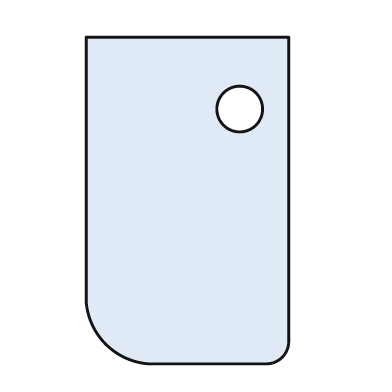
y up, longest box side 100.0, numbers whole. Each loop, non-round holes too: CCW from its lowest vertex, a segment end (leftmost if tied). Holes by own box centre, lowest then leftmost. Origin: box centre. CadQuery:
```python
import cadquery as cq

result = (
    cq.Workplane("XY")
    .moveTo(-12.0, -50.0)
    .lineTo(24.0, -50.0)
    .threePointArc((29.0, -48.0), (31.0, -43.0))
    .lineTo(31.0, 50.0)
    .lineTo(-31.0, 50.0)
    .lineTo(-31.0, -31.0)
    .threePointArc((-25.0, -44.0), (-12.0, -50.0))
    .close()
    .moveTo(16.0, 28.0)
    .circle(7.0)
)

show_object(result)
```